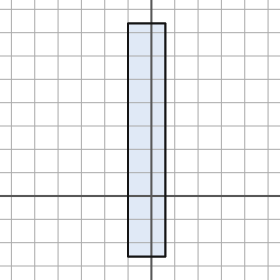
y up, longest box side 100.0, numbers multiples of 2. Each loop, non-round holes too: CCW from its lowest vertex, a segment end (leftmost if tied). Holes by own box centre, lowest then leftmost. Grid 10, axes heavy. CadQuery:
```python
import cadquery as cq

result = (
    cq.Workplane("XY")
    .moveTo(-10.0, -26.0)
    .lineTo(6.0, -26.0)
    .lineTo(6.0, 74.0)
    .lineTo(-10.0, 74.0)
    .close()
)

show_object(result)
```